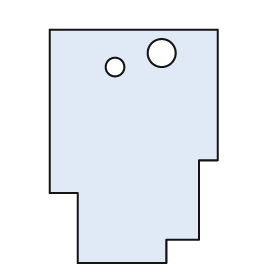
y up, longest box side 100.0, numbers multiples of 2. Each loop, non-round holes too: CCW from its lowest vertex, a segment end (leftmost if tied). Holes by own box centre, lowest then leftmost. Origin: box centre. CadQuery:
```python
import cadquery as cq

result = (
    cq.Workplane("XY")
    .moveTo(-24.0, -50.0)
    .lineTo(14.0, -50.0)
    .lineTo(14.0, -40.0)
    .lineTo(28.0, -40.0)
    .lineTo(28.0, -6.0)
    .lineTo(36.0, -6.0)
    .lineTo(36.0, 50.0)
    .lineTo(-36.0, 50.0)
    .lineTo(-36.0, -20.0)
    .lineTo(-24.0, -20.0)
    .close()
    .moveTo(-8.0, 34.0)
    .circle(4.0)
    .moveTo(12.0, 40.0)
    .circle(6.0)
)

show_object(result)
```